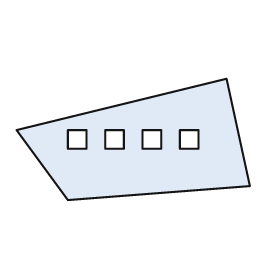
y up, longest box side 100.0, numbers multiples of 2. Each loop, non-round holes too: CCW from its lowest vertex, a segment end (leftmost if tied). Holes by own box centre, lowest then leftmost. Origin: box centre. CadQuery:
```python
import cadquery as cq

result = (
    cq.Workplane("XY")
    .moveTo(-28.0, -26.0)
    .lineTo(50.0, -20.0)
    .lineTo(40.0, 26.0)
    .lineTo(-50.0, 4.0)
    .close()
    .moveTo(-28.0, -4.0)
    .lineTo(-20.0, -4.0)
    .lineTo(-20.0, 4.0)
    .lineTo(-28.0, 4.0)
    .close()
    .moveTo(-12.0, -4.0)
    .lineTo(-4.0, -4.0)
    .lineTo(-4.0, 4.0)
    .lineTo(-12.0, 4.0)
    .close()
    .moveTo(4.0, -4.0)
    .lineTo(12.0, -4.0)
    .lineTo(12.0, 4.0)
    .lineTo(4.0, 4.0)
    .close()
    .moveTo(20.0, -4.0)
    .lineTo(28.0, -4.0)
    .lineTo(28.0, 4.0)
    .lineTo(20.0, 4.0)
    .close()
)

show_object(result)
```